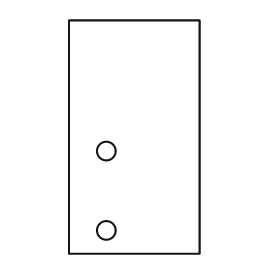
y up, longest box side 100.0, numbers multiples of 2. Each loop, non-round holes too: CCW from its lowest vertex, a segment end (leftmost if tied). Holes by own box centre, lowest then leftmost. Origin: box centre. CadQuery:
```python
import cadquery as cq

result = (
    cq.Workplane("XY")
    .moveTo(-28.0, -50.0)
    .lineTo(28.0, -50.0)
    .lineTo(28.0, 50.0)
    .lineTo(-28.0, 50.0)
    .close()
    .moveTo(-12.0, -40.0)
    .circle(4.0)
    .moveTo(-12.0, -6.0)
    .circle(4.0)
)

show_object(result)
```